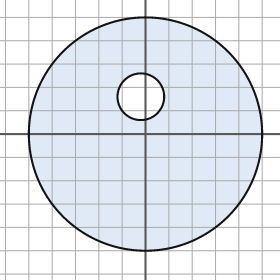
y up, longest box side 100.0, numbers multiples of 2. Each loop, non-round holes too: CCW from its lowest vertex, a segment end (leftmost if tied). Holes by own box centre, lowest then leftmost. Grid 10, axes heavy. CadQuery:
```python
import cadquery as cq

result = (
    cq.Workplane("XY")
    .moveTo(0.0, 0.0)
    .circle(50.0)
    .moveTo(-2.0, 16.0)
    .circle(10.0)
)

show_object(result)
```